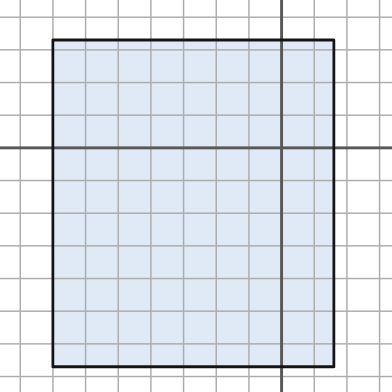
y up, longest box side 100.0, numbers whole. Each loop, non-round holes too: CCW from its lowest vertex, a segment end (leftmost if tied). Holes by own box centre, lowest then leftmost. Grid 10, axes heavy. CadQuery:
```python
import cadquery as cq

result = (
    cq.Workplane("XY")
    .moveTo(-70.0, -67.0)
    .lineTo(16.0, -67.0)
    .lineTo(16.0, 33.0)
    .lineTo(-70.0, 33.0)
    .close()
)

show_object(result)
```